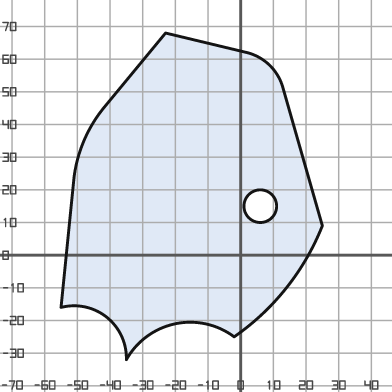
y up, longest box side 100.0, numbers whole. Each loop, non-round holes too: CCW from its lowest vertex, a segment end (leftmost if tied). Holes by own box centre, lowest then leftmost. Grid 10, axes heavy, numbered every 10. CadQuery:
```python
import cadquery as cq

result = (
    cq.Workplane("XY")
    .moveTo(-35.0, -32.0)
    .threePointArc((-20.0, -21.0), (-2.0, -25.0))
    .threePointArc((14.0, -10.0), (25.0, 9.0))
    .lineTo(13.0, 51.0)
    .threePointArc((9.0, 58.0), (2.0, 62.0))
    .lineTo(-23.0, 68.0)
    .lineTo(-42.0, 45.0)
    .threePointArc((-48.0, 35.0), (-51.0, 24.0))
    .lineTo(-55.0, -16.0)
    .threePointArc((-41.0, -19.0), (-35.0, -32.0))
    .close()
    .moveTo(6.0, 15.0)
    .circle(5.0)
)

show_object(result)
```